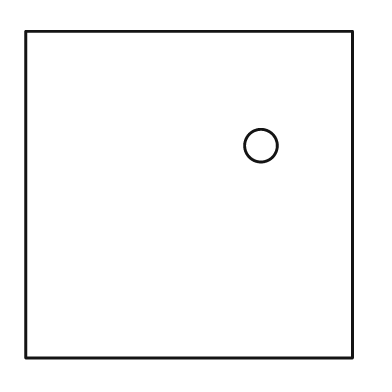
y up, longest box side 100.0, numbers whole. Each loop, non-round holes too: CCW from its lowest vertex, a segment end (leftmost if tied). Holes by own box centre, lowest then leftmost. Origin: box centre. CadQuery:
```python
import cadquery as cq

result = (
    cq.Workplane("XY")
    .moveTo(-50.0, -50.0)
    .lineTo(50.0, -50.0)
    .lineTo(50.0, 50.0)
    .lineTo(-50.0, 50.0)
    .close()
    .moveTo(22.0, 15.0)
    .circle(5.0)
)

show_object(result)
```